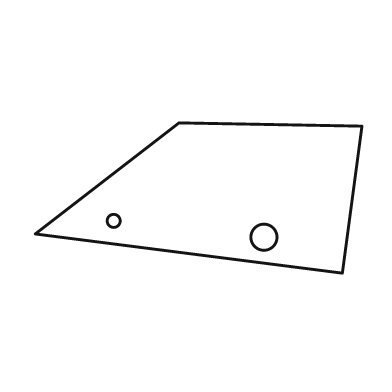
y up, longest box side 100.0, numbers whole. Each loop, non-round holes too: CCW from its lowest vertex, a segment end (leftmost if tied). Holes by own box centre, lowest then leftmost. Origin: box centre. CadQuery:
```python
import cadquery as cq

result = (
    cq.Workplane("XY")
    .moveTo(44.0, -23.0)
    .lineTo(50.0, 22.0)
    .lineTo(-6.0, 23.0)
    .lineTo(-50.0, -11.0)
    .close()
    .moveTo(20.0, -12.0)
    .circle(4.0)
    .moveTo(-26.0, -7.0)
    .circle(2.0)
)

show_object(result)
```